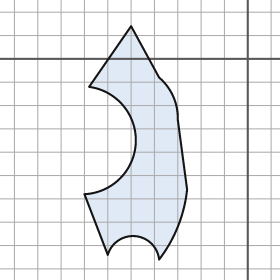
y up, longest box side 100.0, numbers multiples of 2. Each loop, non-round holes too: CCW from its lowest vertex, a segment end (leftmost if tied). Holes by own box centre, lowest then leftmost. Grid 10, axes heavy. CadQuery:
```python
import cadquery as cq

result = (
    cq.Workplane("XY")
    .moveTo(-38.0, -86.0)
    .threePointArc((-30.0, -72.0), (-26.0, -56.0))
    .lineTo(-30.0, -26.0)
    .threePointArc((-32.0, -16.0), (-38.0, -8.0))
    .lineTo(-50.0, 14.0)
    .lineTo(-68.0, -12.0)
    .threePointArc((-48.0, -36.0), (-70.0, -58.0))
    .lineTo(-60.0, -84.0)
    .threePointArc((-48.0, -76.0), (-38.0, -86.0))
    .close()
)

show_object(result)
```